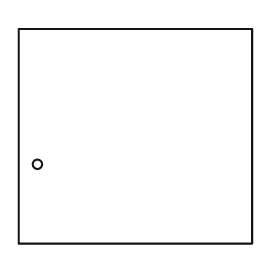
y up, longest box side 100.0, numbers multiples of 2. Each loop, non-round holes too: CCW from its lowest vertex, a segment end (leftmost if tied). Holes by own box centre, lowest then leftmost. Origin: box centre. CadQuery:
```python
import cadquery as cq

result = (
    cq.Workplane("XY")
    .moveTo(-50.0, -46.0)
    .lineTo(50.0, -46.0)
    .lineTo(50.0, 46.0)
    .lineTo(-50.0, 46.0)
    .close()
    .moveTo(-42.0, -12.0)
    .circle(2.0)
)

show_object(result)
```